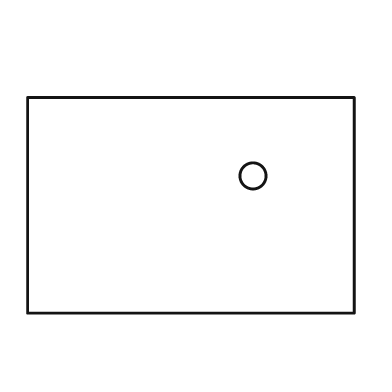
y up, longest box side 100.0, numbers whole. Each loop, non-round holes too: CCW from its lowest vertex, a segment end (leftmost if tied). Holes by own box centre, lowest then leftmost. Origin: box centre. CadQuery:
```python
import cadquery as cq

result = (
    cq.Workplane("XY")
    .moveTo(-50.0, -33.0)
    .lineTo(50.0, -33.0)
    .lineTo(50.0, 33.0)
    .lineTo(-50.0, 33.0)
    .close()
    .moveTo(19.0, 9.0)
    .circle(4.0)
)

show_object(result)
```